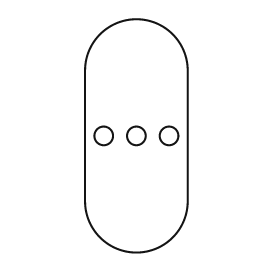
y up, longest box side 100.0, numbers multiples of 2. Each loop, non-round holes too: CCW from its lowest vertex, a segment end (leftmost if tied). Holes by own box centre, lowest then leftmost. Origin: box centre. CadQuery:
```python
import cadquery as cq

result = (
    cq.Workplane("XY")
    .moveTo(-22.0, -28.0)
    .threePointArc((0.0, -50.0), (22.0, -28.0))
    .lineTo(22.0, 28.0)
    .threePointArc((0.0, 50.0), (-22.0, 28.0))
    .close()
    .moveTo(-14.0, 0.0)
    .circle(4.0)
    .moveTo(0.0, 0.0)
    .circle(4.0)
    .moveTo(14.0, 0.0)
    .circle(4.0)
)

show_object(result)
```